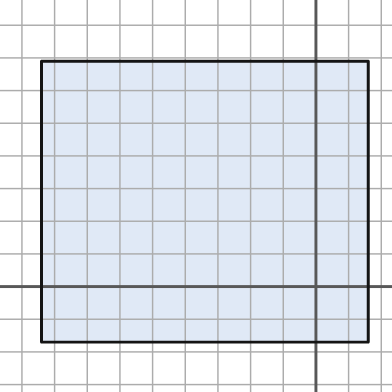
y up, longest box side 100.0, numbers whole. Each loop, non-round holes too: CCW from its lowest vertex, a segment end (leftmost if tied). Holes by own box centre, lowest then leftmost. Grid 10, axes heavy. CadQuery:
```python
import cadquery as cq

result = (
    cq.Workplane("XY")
    .moveTo(-84.0, -17.0)
    .lineTo(16.0, -17.0)
    .lineTo(16.0, 69.0)
    .lineTo(-84.0, 69.0)
    .close()
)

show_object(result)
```